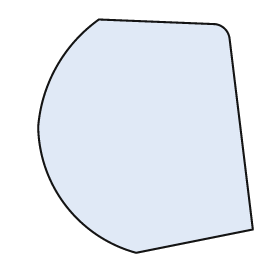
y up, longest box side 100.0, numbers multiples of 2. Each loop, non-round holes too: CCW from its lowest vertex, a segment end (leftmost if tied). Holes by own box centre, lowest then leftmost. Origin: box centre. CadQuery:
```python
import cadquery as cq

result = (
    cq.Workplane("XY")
    .moveTo(-4.0, -50.0)
    .lineTo(46.0, -40.0)
    .lineTo(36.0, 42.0)
    .threePointArc((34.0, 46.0), (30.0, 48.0))
    .lineTo(-20.0, 50.0)
    .threePointArc((-38.0, 30.0), (-46.0, 4.0))
    .threePointArc((-34.0, -30.0), (-4.0, -50.0))
    .close()
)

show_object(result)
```